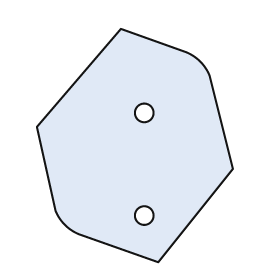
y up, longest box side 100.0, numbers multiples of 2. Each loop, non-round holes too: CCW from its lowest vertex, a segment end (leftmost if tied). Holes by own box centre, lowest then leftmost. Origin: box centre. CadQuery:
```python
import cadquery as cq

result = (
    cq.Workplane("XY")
    .moveTo(10.0, -50.0)
    .lineTo(42.0, -10.0)
    .lineTo(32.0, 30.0)
    .threePointArc((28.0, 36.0), (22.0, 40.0))
    .lineTo(-6.0, 50.0)
    .lineTo(-42.0, 8.0)
    .lineTo(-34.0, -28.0)
    .threePointArc((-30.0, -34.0), (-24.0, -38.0))
    .close()
    .moveTo(4.0, -30.0)
    .circle(4.0)
    .moveTo(4.0, 14.0)
    .circle(4.0)
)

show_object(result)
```